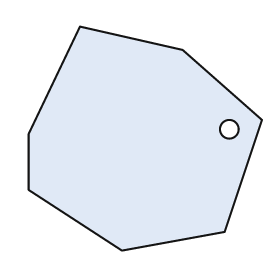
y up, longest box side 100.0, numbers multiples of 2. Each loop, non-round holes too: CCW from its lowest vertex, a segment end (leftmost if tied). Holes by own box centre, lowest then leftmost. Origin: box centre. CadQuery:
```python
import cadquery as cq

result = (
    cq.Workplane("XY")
    .moveTo(-10.0, -48.0)
    .lineTo(34.0, -40.0)
    .lineTo(50.0, 8.0)
    .lineTo(16.0, 38.0)
    .lineTo(-28.0, 48.0)
    .lineTo(-50.0, 2.0)
    .lineTo(-50.0, -22.0)
    .close()
    .moveTo(36.0, 4.0)
    .circle(4.0)
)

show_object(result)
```